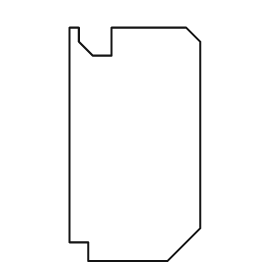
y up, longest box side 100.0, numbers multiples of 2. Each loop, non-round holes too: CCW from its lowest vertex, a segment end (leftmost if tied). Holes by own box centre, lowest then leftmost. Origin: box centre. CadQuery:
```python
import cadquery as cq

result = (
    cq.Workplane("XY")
    .moveTo(-20.0, -50.0)
    .lineTo(14.0, -50.0)
    .lineTo(28.0, -36.0)
    .lineTo(28.0, 44.0)
    .lineTo(22.0, 50.0)
    .lineTo(-10.0, 50.0)
    .lineTo(-10.0, 38.0)
    .lineTo(-18.0, 38.0)
    .lineTo(-24.0, 44.0)
    .lineTo(-24.0, 50.0)
    .lineTo(-28.0, 50.0)
    .lineTo(-28.0, -42.0)
    .lineTo(-20.0, -42.0)
    .close()
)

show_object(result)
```